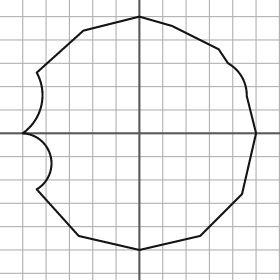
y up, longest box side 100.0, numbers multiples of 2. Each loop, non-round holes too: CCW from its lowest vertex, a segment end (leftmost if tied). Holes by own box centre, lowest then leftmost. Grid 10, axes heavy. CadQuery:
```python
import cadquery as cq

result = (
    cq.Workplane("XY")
    .moveTo(0.0, -50.0)
    .lineTo(26.0, -44.0)
    .lineTo(44.0, -26.0)
    .lineTo(50.0, 0.0)
    .lineTo(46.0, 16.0)
    .threePointArc((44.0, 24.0), (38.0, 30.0))
    .lineTo(34.0, 36.0)
    .lineTo(14.0, 46.0)
    .lineTo(0.0, 50.0)
    .lineTo(-24.0, 44.0)
    .lineTo(-44.0, 26.0)
    .threePointArc((-42.0, 12.0), (-50.0, 0.0))
    .threePointArc((-38.0, -10.0), (-44.0, -24.0))
    .lineTo(-26.0, -44.0)
    .close()
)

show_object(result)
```